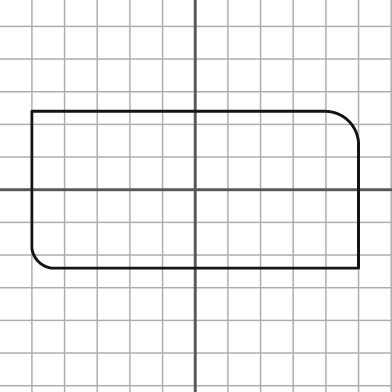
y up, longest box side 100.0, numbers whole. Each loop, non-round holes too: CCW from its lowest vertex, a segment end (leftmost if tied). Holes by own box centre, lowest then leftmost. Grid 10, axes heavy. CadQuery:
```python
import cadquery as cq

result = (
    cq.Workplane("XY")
    .moveTo(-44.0, -24.0)
    .lineTo(50.0, -24.0)
    .lineTo(50.0, 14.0)
    .threePointArc((47.0, 21.0), (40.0, 24.0))
    .lineTo(-50.0, 24.0)
    .lineTo(-50.0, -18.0)
    .threePointArc((-48.0, -22.0), (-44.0, -24.0))
    .close()
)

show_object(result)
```